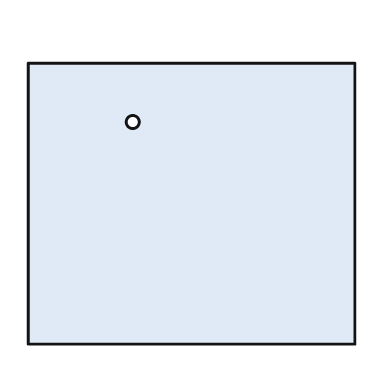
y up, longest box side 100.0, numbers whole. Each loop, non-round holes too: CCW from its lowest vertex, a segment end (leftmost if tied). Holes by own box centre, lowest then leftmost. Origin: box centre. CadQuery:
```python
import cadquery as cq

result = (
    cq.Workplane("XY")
    .moveTo(-50.0, -43.0)
    .lineTo(50.0, -43.0)
    .lineTo(50.0, 43.0)
    .lineTo(-50.0, 43.0)
    .close()
    .moveTo(-18.0, 25.0)
    .circle(2.0)
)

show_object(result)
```